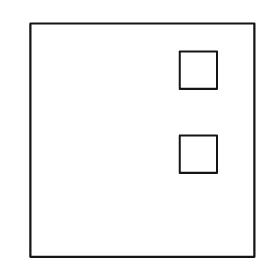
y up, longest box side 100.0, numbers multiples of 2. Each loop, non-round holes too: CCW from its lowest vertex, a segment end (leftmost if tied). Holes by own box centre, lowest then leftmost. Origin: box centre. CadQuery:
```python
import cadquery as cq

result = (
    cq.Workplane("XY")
    .moveTo(-48.0, -50.0)
    .lineTo(48.0, -50.0)
    .lineTo(48.0, 50.0)
    .lineTo(-48.0, 50.0)
    .close()
    .moveTo(16.0, -14.0)
    .lineTo(32.0, -14.0)
    .lineTo(32.0, 2.0)
    .lineTo(16.0, 2.0)
    .close()
    .moveTo(16.0, 22.0)
    .lineTo(32.0, 22.0)
    .lineTo(32.0, 38.0)
    .lineTo(16.0, 38.0)
    .close()
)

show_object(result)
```